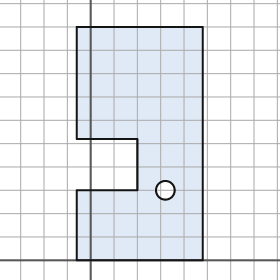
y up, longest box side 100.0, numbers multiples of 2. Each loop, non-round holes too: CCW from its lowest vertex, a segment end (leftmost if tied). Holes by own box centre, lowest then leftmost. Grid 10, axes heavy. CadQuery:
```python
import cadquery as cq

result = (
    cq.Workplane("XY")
    .moveTo(-6.0, 0.0)
    .lineTo(48.0, 0.0)
    .lineTo(48.0, 100.0)
    .lineTo(-6.0, 100.0)
    .lineTo(-6.0, 52.0)
    .lineTo(20.0, 52.0)
    .lineTo(20.0, 30.0)
    .lineTo(-6.0, 30.0)
    .close()
    .moveTo(32.0, 30.0)
    .circle(4.0)
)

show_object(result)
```